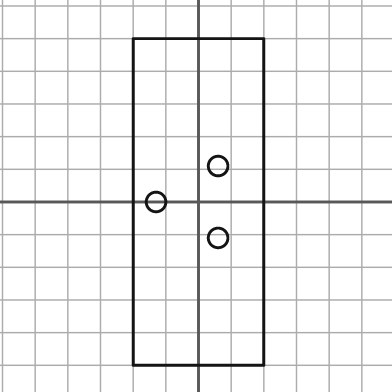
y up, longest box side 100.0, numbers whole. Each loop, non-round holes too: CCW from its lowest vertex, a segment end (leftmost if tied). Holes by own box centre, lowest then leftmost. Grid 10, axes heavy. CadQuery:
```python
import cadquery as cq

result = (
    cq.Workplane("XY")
    .moveTo(-20.0, -50.0)
    .lineTo(20.0, -50.0)
    .lineTo(20.0, 50.0)
    .lineTo(-20.0, 50.0)
    .close()
    .moveTo(6.0, -11.0)
    .circle(3.0)
    .moveTo(-13.0, 0.0)
    .circle(3.0)
    .moveTo(6.0, 11.0)
    .circle(3.0)
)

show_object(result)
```